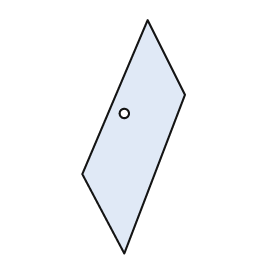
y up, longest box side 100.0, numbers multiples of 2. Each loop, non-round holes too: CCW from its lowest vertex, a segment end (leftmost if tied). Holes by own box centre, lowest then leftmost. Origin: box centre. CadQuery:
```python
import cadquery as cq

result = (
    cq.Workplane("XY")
    .moveTo(-4.0, -50.0)
    .lineTo(22.0, 18.0)
    .lineTo(6.0, 50.0)
    .lineTo(-22.0, -16.0)
    .close()
    .moveTo(-4.0, 10.0)
    .circle(2.0)
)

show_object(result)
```